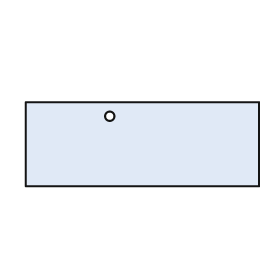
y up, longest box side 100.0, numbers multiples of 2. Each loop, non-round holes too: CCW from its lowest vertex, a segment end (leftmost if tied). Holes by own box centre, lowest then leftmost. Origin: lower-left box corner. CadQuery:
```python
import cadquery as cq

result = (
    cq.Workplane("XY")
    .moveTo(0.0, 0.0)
    .lineTo(100.0, 0.0)
    .lineTo(100.0, 36.0)
    .lineTo(0.0, 36.0)
    .close()
    .moveTo(36.0, 30.0)
    .circle(2.0)
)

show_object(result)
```